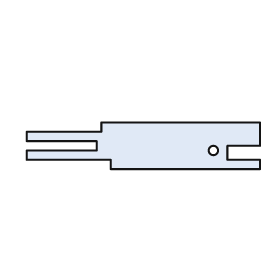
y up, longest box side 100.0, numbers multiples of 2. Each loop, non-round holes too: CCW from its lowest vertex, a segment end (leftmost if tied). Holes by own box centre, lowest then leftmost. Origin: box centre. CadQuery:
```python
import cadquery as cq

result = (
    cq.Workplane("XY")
    .moveTo(-14.0, -10.0)
    .lineTo(50.0, -10.0)
    .lineTo(50.0, -6.0)
    .lineTo(36.0, -6.0)
    .lineTo(36.0, 0.0)
    .lineTo(50.0, 0.0)
    .lineTo(50.0, 10.0)
    .lineTo(-18.0, 10.0)
    .lineTo(-18.0, 6.0)
    .lineTo(-50.0, 6.0)
    .lineTo(-50.0, 2.0)
    .lineTo(-20.0, 2.0)
    .lineTo(-20.0, -2.0)
    .lineTo(-50.0, -2.0)
    .lineTo(-50.0, -6.0)
    .lineTo(-14.0, -6.0)
    .close()
    .moveTo(30.0, -2.0)
    .circle(2.0)
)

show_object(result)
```